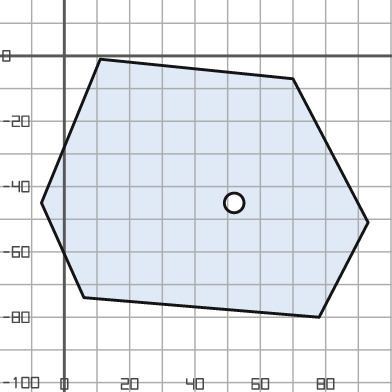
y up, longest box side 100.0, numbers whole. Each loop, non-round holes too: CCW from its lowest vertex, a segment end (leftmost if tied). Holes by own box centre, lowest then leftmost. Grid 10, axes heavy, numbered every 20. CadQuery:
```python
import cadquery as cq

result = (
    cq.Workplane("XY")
    .moveTo(78.0, -80.0)
    .lineTo(93.0, -51.0)
    .lineTo(70.0, -7.0)
    .lineTo(11.0, -1.0)
    .lineTo(-7.0, -45.0)
    .lineTo(6.0, -74.0)
    .close()
    .moveTo(52.0, -45.0)
    .circle(3.0)
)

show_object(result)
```